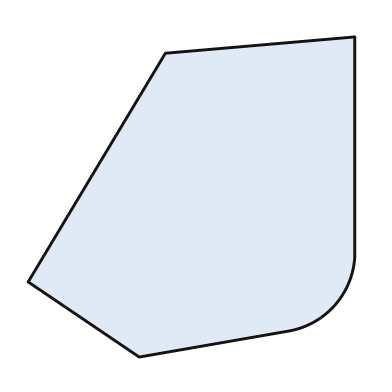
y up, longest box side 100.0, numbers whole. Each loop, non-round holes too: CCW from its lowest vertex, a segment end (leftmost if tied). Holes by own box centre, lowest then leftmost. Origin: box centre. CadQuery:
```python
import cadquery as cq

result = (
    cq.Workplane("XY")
    .moveTo(-16.0, -49.0)
    .lineTo(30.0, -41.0)
    .threePointArc((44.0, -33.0), (50.0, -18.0))
    .lineTo(50.0, 49.0)
    .lineTo(-8.0, 44.0)
    .lineTo(-50.0, -26.0)
    .close()
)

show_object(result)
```